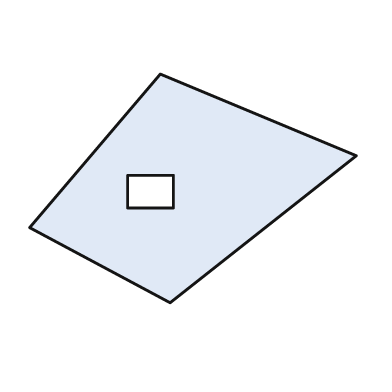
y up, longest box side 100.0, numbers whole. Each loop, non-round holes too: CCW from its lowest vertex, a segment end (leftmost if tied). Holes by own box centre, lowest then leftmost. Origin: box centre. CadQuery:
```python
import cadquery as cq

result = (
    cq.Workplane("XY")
    .moveTo(-7.0, -35.0)
    .lineTo(50.0, 10.0)
    .lineTo(-10.0, 35.0)
    .lineTo(-50.0, -12.0)
    .close()
    .moveTo(-20.0, -6.0)
    .lineTo(-6.0, -6.0)
    .lineTo(-6.0, 4.0)
    .lineTo(-20.0, 4.0)
    .close()
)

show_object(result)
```